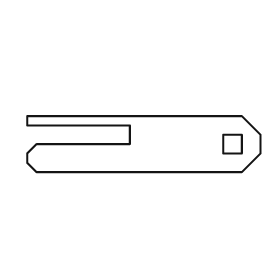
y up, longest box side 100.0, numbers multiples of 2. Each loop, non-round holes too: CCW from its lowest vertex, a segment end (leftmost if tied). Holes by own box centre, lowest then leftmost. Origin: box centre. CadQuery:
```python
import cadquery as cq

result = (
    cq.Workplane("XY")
    .moveTo(-46.0, -12.0)
    .lineTo(42.0, -12.0)
    .lineTo(50.0, -4.0)
    .lineTo(50.0, 4.0)
    .lineTo(42.0, 12.0)
    .lineTo(-50.0, 12.0)
    .lineTo(-50.0, 8.0)
    .lineTo(-6.0, 8.0)
    .lineTo(-6.0, 0.0)
    .lineTo(-46.0, 0.0)
    .lineTo(-50.0, -4.0)
    .lineTo(-50.0, -8.0)
    .close()
    .moveTo(34.0, -4.0)
    .lineTo(42.0, -4.0)
    .lineTo(42.0, 4.0)
    .lineTo(34.0, 4.0)
    .close()
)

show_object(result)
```